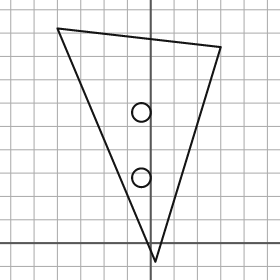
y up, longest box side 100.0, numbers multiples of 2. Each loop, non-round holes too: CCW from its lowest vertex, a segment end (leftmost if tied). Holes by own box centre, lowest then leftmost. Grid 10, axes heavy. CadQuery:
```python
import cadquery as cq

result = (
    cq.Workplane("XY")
    .moveTo(2.0, -8.0)
    .lineTo(30.0, 84.0)
    .lineTo(-40.0, 92.0)
    .close()
    .moveTo(-4.0, 28.0)
    .circle(4.0)
    .moveTo(-4.0, 56.0)
    .circle(4.0)
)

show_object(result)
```